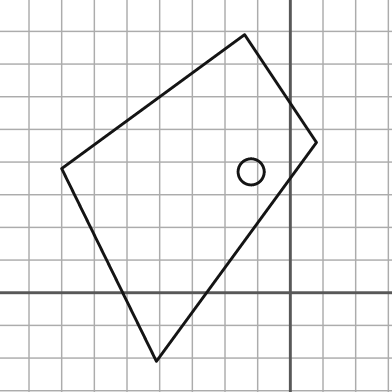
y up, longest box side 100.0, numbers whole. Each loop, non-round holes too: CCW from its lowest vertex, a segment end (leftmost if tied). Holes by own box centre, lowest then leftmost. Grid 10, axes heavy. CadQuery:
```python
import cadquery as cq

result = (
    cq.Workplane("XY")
    .moveTo(-41.0, -21.0)
    .lineTo(8.0, 46.0)
    .lineTo(-14.0, 79.0)
    .lineTo(-70.0, 38.0)
    .close()
    .moveTo(-12.0, 37.0)
    .circle(4.0)
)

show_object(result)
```